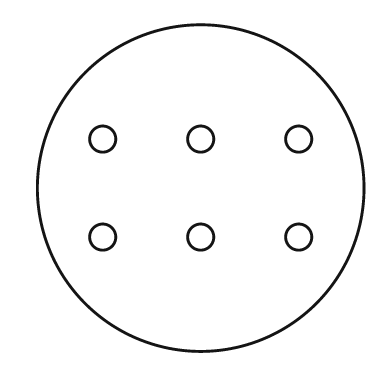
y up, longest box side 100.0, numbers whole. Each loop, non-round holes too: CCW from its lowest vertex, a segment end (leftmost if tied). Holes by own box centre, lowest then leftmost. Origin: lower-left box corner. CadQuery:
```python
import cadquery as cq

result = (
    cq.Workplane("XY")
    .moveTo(50.0, 50.0)
    .circle(50.0)
    .moveTo(20.0, 35.0)
    .circle(4.0)
    .moveTo(50.0, 35.0)
    .circle(4.0)
    .moveTo(80.0, 35.0)
    .circle(4.0)
    .moveTo(20.0, 65.0)
    .circle(4.0)
    .moveTo(50.0, 65.0)
    .circle(4.0)
    .moveTo(80.0, 65.0)
    .circle(4.0)
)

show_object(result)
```